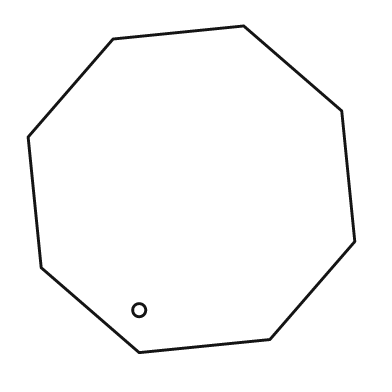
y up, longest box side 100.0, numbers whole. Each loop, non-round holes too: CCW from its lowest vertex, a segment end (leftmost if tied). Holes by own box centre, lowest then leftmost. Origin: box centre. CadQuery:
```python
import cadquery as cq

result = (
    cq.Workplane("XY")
    .moveTo(-16.0, -50.0)
    .lineTo(24.0, -46.0)
    .lineTo(50.0, -16.0)
    .lineTo(46.0, 24.0)
    .lineTo(16.0, 50.0)
    .lineTo(-24.0, 46.0)
    .lineTo(-50.0, 16.0)
    .lineTo(-46.0, -24.0)
    .close()
    .moveTo(-16.0, -37.0)
    .circle(2.0)
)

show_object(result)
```